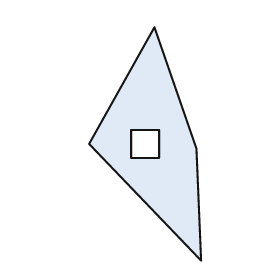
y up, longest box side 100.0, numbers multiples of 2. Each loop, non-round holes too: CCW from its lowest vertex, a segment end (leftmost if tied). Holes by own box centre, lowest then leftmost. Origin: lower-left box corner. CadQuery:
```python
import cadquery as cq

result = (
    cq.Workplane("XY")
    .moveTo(48.0, 0.0)
    .lineTo(46.0, 48.0)
    .lineTo(28.0, 100.0)
    .lineTo(0.0, 50.0)
    .close()
    .moveTo(18.0, 44.0)
    .lineTo(30.0, 44.0)
    .lineTo(30.0, 56.0)
    .lineTo(18.0, 56.0)
    .close()
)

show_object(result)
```